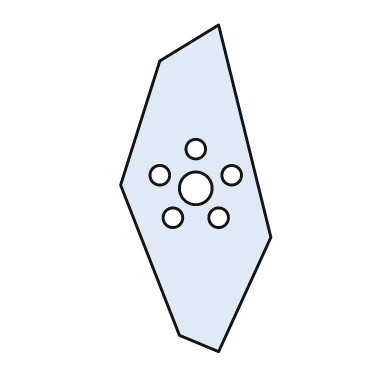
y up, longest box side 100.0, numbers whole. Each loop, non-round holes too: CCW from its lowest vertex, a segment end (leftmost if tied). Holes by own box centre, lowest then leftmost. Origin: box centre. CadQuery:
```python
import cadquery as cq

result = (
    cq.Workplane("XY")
    .moveTo(7.0, -50.0)
    .lineTo(23.0, -15.0)
    .lineTo(7.0, 50.0)
    .lineTo(-11.0, 39.0)
    .lineTo(-23.0, 1.0)
    .lineTo(-5.0, -45.0)
    .close()
    .moveTo(-7.0, -9.0)
    .circle(3.0)
    .moveTo(7.0, -9.0)
    .circle(3.0)
    .moveTo(0.0, 0.0)
    .circle(5.0)
    .moveTo(-11.0, 4.0)
    .circle(3.0)
    .moveTo(11.0, 4.0)
    .circle(3.0)
    .moveTo(0.0, 12.0)
    .circle(3.0)
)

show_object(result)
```